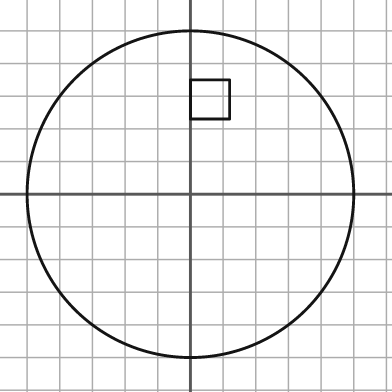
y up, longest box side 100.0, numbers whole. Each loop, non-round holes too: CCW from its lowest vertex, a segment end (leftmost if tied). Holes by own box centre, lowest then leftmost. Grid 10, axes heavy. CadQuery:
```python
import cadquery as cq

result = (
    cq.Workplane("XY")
    .moveTo(0.0, 0.0)
    .circle(50.0)
    .moveTo(0.0, 23.0)
    .lineTo(12.0, 23.0)
    .lineTo(12.0, 35.0)
    .lineTo(0.0, 35.0)
    .close()
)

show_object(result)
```